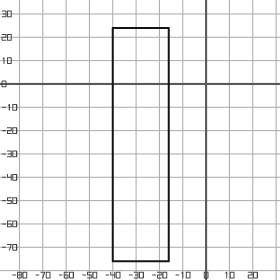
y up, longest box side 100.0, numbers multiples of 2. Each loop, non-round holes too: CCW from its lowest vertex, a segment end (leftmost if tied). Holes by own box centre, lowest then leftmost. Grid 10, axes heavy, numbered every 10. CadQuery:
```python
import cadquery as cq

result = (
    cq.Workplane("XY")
    .moveTo(-40.0, -76.0)
    .lineTo(-16.0, -76.0)
    .lineTo(-16.0, 24.0)
    .lineTo(-40.0, 24.0)
    .close()
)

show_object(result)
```